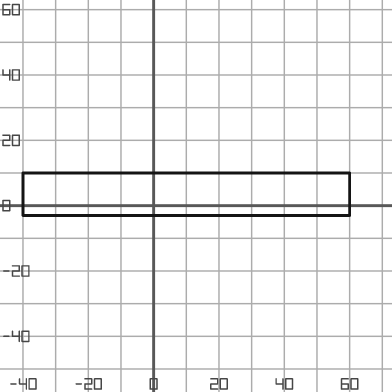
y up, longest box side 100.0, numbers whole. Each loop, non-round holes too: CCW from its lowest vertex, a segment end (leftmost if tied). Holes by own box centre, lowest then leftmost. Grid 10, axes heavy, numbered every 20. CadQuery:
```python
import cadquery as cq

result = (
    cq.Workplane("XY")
    .moveTo(-40.0, -3.0)
    .lineTo(60.0, -3.0)
    .lineTo(60.0, 10.0)
    .lineTo(-40.0, 10.0)
    .close()
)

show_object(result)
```